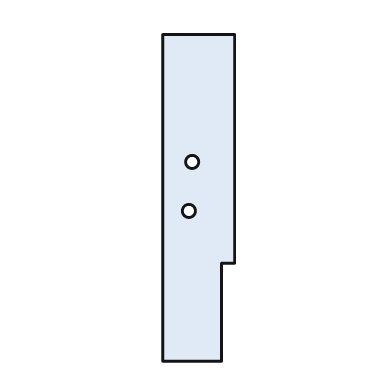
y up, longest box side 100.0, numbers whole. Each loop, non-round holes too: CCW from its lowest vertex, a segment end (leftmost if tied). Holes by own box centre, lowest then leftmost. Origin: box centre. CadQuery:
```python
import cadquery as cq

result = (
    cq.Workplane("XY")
    .moveTo(-11.0, -50.0)
    .lineTo(7.0, -50.0)
    .lineTo(7.0, -20.0)
    .lineTo(11.0, -20.0)
    .lineTo(11.0, 50.0)
    .lineTo(-11.0, 50.0)
    .close()
    .moveTo(-3.0, -4.0)
    .circle(2.0)
    .moveTo(-2.0, 11.0)
    .circle(2.0)
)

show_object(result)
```